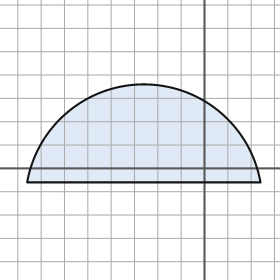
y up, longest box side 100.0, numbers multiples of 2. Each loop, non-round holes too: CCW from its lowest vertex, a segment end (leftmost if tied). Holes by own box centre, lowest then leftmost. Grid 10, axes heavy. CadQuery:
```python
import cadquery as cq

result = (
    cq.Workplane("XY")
    .moveTo(-76.0, -6.0)
    .lineTo(24.0, -6.0)
    .threePointArc((-26.0, 36.0), (-76.0, -6.0))
    .close()
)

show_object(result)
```